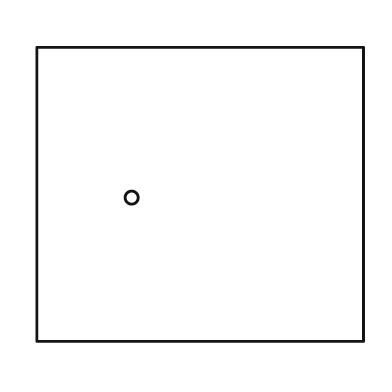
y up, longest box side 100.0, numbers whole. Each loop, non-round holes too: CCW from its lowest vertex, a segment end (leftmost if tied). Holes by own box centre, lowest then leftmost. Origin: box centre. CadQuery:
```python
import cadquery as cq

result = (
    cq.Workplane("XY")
    .moveTo(-50.0, -45.0)
    .lineTo(50.0, -45.0)
    .lineTo(50.0, 45.0)
    .lineTo(-50.0, 45.0)
    .close()
    .moveTo(-21.0, -1.0)
    .circle(2.0)
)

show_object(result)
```